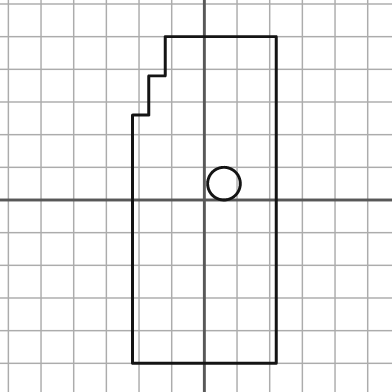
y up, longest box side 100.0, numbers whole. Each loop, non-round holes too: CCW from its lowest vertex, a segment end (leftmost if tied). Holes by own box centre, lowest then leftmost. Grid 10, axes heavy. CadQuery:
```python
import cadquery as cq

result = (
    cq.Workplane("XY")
    .moveTo(-22.0, -50.0)
    .lineTo(22.0, -50.0)
    .lineTo(22.0, 50.0)
    .lineTo(-12.0, 50.0)
    .lineTo(-12.0, 38.0)
    .lineTo(-17.0, 38.0)
    .lineTo(-17.0, 26.0)
    .lineTo(-22.0, 26.0)
    .close()
    .moveTo(6.0, 5.0)
    .circle(5.0)
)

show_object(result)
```